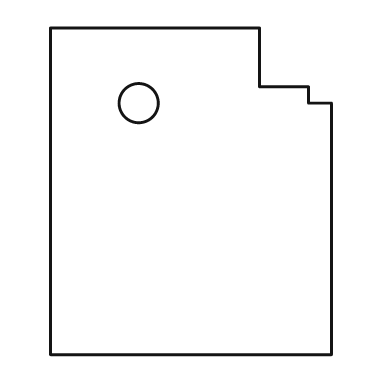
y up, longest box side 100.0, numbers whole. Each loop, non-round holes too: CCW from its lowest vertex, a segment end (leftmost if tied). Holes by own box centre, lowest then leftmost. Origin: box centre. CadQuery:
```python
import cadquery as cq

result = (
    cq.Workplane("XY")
    .moveTo(-43.0, -50.0)
    .lineTo(43.0, -50.0)
    .lineTo(43.0, 27.0)
    .lineTo(36.0, 27.0)
    .lineTo(36.0, 32.0)
    .lineTo(21.0, 32.0)
    .lineTo(21.0, 50.0)
    .lineTo(-43.0, 50.0)
    .close()
    .moveTo(-16.0, 27.0)
    .circle(6.0)
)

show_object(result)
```